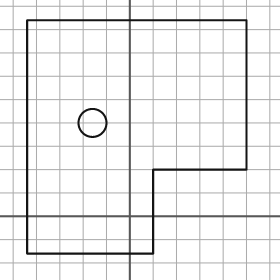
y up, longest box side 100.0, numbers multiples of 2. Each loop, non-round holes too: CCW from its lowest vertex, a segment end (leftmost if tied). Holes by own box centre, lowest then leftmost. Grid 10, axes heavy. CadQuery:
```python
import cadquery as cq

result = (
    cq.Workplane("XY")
    .moveTo(-44.0, -16.0)
    .lineTo(10.0, -16.0)
    .lineTo(10.0, 20.0)
    .lineTo(50.0, 20.0)
    .lineTo(50.0, 84.0)
    .lineTo(-44.0, 84.0)
    .close()
    .moveTo(-16.0, 40.0)
    .circle(6.0)
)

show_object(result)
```